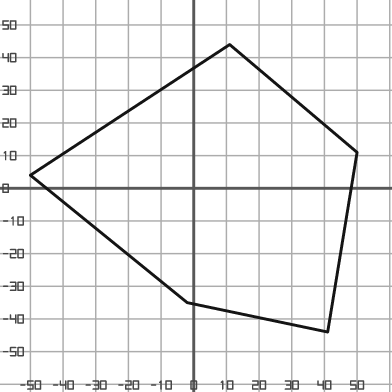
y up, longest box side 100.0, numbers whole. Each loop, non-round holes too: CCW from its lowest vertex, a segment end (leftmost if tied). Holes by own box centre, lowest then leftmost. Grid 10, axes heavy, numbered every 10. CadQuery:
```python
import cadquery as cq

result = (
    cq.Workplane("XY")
    .moveTo(41.0, -44.0)
    .lineTo(50.0, 11.0)
    .lineTo(11.0, 44.0)
    .lineTo(-50.0, 4.0)
    .lineTo(-2.0, -35.0)
    .close()
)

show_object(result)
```